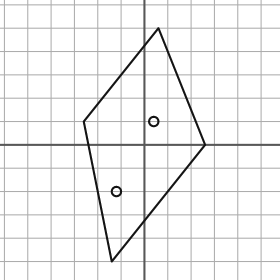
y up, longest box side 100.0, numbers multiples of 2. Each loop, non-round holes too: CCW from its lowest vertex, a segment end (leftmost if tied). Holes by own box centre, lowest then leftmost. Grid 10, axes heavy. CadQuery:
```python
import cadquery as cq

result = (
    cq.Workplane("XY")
    .moveTo(-14.0, -50.0)
    .lineTo(26.0, 0.0)
    .lineTo(6.0, 50.0)
    .lineTo(-26.0, 10.0)
    .close()
    .moveTo(-12.0, -20.0)
    .circle(2.0)
    .moveTo(4.0, 10.0)
    .circle(2.0)
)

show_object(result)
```